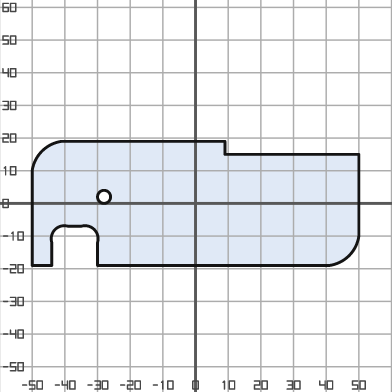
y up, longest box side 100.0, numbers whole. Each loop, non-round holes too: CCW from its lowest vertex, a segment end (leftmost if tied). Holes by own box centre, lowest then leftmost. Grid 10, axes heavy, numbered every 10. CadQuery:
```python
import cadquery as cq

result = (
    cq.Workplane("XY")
    .moveTo(-50.0, -19.0)
    .lineTo(-44.0, -19.0)
    .lineTo(-44.0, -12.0)
    .threePointArc((-43.0, -8.0), (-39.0, -7.0))
    .lineTo(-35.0, -7.0)
    .threePointArc((-31.0, -8.0), (-30.0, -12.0))
    .lineTo(-30.0, -19.0)
    .lineTo(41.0, -19.0)
    .threePointArc((47.0, -16.0), (50.0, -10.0))
    .lineTo(50.0, 15.0)
    .lineTo(9.0, 15.0)
    .lineTo(9.0, 19.0)
    .lineTo(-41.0, 19.0)
    .threePointArc((-47.0, 16.0), (-50.0, 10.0))
    .close()
    .moveTo(-28.0, 2.0)
    .circle(2.0)
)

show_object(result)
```